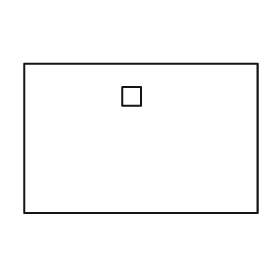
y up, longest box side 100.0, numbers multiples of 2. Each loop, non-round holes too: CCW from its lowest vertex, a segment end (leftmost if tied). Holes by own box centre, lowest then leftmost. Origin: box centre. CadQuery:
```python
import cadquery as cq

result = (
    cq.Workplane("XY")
    .moveTo(-50.0, -32.0)
    .lineTo(50.0, -32.0)
    .lineTo(50.0, 32.0)
    .lineTo(-50.0, 32.0)
    .close()
    .moveTo(-8.0, 14.0)
    .lineTo(0.0, 14.0)
    .lineTo(0.0, 22.0)
    .lineTo(-8.0, 22.0)
    .close()
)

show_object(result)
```